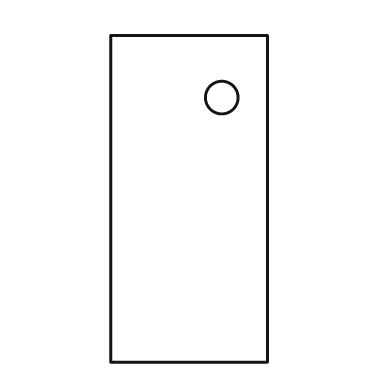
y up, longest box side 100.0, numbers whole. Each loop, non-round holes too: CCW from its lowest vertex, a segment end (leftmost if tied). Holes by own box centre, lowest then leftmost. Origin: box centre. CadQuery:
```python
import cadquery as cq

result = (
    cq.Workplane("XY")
    .moveTo(-24.0, -50.0)
    .lineTo(24.0, -50.0)
    .lineTo(24.0, 50.0)
    .lineTo(-24.0, 50.0)
    .close()
    .moveTo(10.0, 31.0)
    .circle(5.0)
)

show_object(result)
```